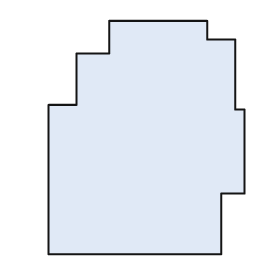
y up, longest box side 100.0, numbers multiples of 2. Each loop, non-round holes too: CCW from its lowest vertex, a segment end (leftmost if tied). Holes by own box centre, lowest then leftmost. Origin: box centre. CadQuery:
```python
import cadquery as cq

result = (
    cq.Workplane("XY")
    .moveTo(-42.0, -50.0)
    .lineTo(32.0, -50.0)
    .lineTo(32.0, -24.0)
    .lineTo(42.0, -24.0)
    .lineTo(42.0, 12.0)
    .lineTo(38.0, 12.0)
    .lineTo(38.0, 42.0)
    .lineTo(26.0, 42.0)
    .lineTo(26.0, 50.0)
    .lineTo(-16.0, 50.0)
    .lineTo(-16.0, 36.0)
    .lineTo(-30.0, 36.0)
    .lineTo(-30.0, 14.0)
    .lineTo(-42.0, 14.0)
    .close()
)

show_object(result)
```